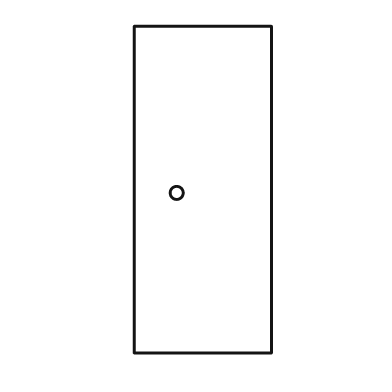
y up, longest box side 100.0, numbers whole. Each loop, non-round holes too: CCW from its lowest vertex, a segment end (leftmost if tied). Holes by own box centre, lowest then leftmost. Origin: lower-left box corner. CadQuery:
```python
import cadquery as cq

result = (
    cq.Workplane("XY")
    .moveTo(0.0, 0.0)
    .lineTo(42.0, 0.0)
    .lineTo(42.0, 100.0)
    .lineTo(0.0, 100.0)
    .close()
    .moveTo(13.0, 49.0)
    .circle(2.0)
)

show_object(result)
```